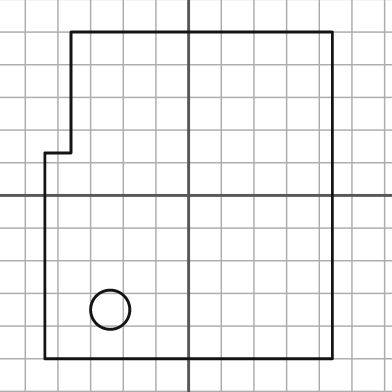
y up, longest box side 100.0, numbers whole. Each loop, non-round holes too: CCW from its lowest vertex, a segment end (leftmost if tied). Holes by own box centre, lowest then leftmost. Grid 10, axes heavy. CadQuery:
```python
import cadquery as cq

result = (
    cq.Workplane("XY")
    .moveTo(-44.0, -50.0)
    .lineTo(44.0, -50.0)
    .lineTo(44.0, 50.0)
    .lineTo(-36.0, 50.0)
    .lineTo(-36.0, 13.0)
    .lineTo(-44.0, 13.0)
    .close()
    .moveTo(-24.0, -35.0)
    .circle(6.0)
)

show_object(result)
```